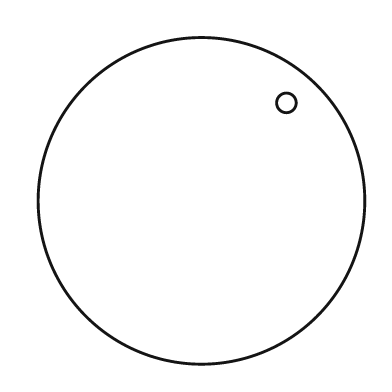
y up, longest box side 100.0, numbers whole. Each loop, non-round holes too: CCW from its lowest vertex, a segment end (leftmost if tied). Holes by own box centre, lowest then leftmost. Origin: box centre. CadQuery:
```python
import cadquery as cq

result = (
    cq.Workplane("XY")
    .moveTo(0.0, 0.0)
    .circle(50.0)
    .moveTo(26.0, 30.0)
    .circle(3.0)
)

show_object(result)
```